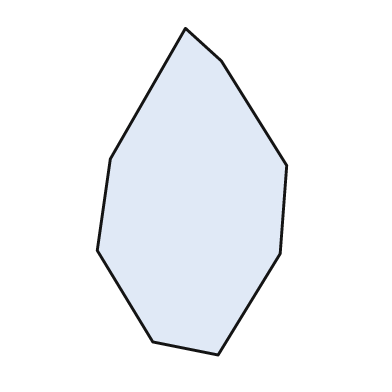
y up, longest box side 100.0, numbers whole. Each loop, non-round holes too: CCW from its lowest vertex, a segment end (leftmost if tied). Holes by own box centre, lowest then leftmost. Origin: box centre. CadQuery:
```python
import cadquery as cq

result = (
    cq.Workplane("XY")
    .moveTo(8.0, -50.0)
    .lineTo(27.0, -19.0)
    .lineTo(29.0, 8.0)
    .lineTo(9.0, 40.0)
    .lineTo(-2.0, 50.0)
    .lineTo(-25.0, 10.0)
    .lineTo(-29.0, -18.0)
    .lineTo(-12.0, -46.0)
    .close()
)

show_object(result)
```